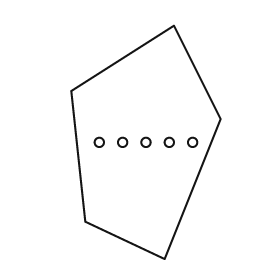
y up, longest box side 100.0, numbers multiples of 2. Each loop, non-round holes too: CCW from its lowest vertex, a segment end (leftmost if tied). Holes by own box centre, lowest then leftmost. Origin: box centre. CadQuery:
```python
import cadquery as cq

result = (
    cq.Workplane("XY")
    .moveTo(8.0, -50.0)
    .lineTo(32.0, 10.0)
    .lineTo(12.0, 50.0)
    .lineTo(-32.0, 22.0)
    .lineTo(-26.0, -34.0)
    .close()
    .moveTo(-20.0, 0.0)
    .circle(2.0)
    .moveTo(-10.0, 0.0)
    .circle(2.0)
    .moveTo(0.0, 0.0)
    .circle(2.0)
    .moveTo(10.0, 0.0)
    .circle(2.0)
    .moveTo(20.0, 0.0)
    .circle(2.0)
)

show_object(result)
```